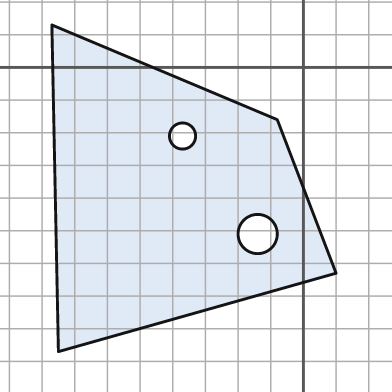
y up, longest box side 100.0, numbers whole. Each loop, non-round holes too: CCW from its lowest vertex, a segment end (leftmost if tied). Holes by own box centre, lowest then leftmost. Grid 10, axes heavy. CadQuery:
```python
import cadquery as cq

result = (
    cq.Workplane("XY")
    .moveTo(-75.0, -87.0)
    .lineTo(10.0, -63.0)
    .lineTo(-8.0, -16.0)
    .lineTo(-77.0, 13.0)
    .close()
    .moveTo(-14.0, -51.0)
    .circle(6.0)
    .moveTo(-37.0, -21.0)
    .circle(4.0)
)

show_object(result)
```